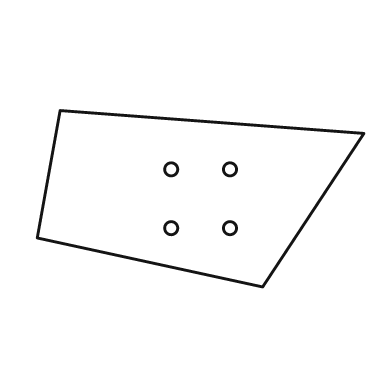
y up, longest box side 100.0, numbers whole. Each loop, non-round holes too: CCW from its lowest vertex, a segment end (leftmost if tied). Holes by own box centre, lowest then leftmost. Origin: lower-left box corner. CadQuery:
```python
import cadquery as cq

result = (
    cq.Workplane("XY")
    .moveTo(69.0, 0.0)
    .lineTo(100.0, 47.0)
    .lineTo(7.0, 54.0)
    .lineTo(0.0, 15.0)
    .close()
    .moveTo(41.0, 18.0)
    .circle(2.0)
    .moveTo(59.0, 18.0)
    .circle(2.0)
    .moveTo(41.0, 36.0)
    .circle(2.0)
    .moveTo(59.0, 36.0)
    .circle(2.0)
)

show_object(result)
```